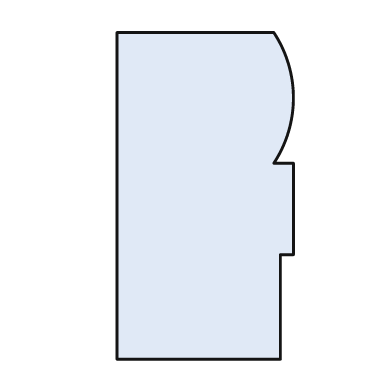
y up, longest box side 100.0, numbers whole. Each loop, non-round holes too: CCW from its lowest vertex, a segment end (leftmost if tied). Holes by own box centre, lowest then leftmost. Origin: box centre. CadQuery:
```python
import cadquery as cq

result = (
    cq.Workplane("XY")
    .moveTo(-27.0, -50.0)
    .lineTo(23.0, -50.0)
    .lineTo(23.0, -18.0)
    .lineTo(27.0, -18.0)
    .lineTo(27.0, 10.0)
    .lineTo(21.0, 10.0)
    .threePointArc((27.0, 30.0), (21.0, 50.0))
    .lineTo(-27.0, 50.0)
    .close()
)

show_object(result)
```